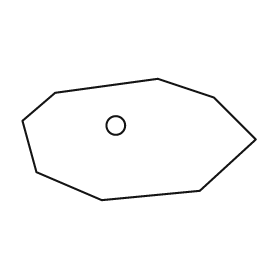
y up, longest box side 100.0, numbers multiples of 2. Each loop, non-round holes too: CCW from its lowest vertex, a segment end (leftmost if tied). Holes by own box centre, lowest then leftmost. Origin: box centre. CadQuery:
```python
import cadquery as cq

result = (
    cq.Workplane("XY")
    .moveTo(-16.0, -26.0)
    .lineTo(26.0, -22.0)
    .lineTo(50.0, 0.0)
    .lineTo(32.0, 18.0)
    .lineTo(8.0, 26.0)
    .lineTo(-36.0, 20.0)
    .lineTo(-50.0, 8.0)
    .lineTo(-44.0, -14.0)
    .close()
    .moveTo(-10.0, 6.0)
    .circle(4.0)
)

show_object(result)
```